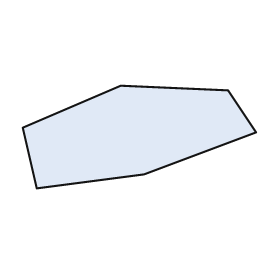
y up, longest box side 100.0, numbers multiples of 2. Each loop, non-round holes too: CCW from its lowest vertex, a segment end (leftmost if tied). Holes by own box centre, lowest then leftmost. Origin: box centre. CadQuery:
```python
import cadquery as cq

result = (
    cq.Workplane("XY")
    .moveTo(-44.0, -22.0)
    .lineTo(2.0, -16.0)
    .lineTo(50.0, 2.0)
    .lineTo(38.0, 20.0)
    .lineTo(-8.0, 22.0)
    .lineTo(-50.0, 4.0)
    .close()
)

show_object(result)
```